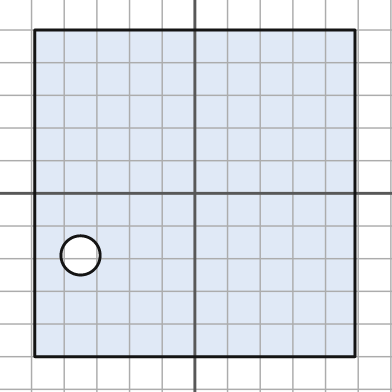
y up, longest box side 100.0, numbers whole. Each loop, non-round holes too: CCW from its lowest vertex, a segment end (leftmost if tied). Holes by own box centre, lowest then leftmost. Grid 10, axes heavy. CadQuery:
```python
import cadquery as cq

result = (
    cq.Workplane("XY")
    .moveTo(-49.0, -50.0)
    .lineTo(49.0, -50.0)
    .lineTo(49.0, 50.0)
    .lineTo(-49.0, 50.0)
    .close()
    .moveTo(-35.0, -19.0)
    .circle(6.0)
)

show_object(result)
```